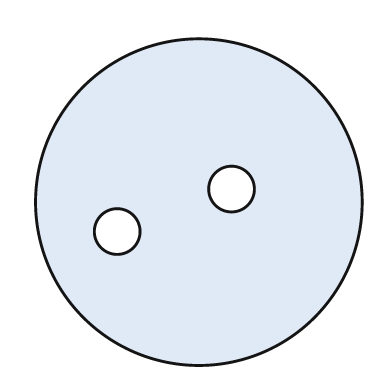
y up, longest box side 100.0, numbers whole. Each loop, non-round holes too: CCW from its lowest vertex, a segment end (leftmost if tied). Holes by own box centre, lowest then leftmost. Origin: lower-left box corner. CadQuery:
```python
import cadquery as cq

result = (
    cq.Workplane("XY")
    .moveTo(50.0, 50.0)
    .circle(50.0)
    .moveTo(25.0, 41.0)
    .circle(7.0)
    .moveTo(60.0, 54.0)
    .circle(7.0)
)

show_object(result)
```